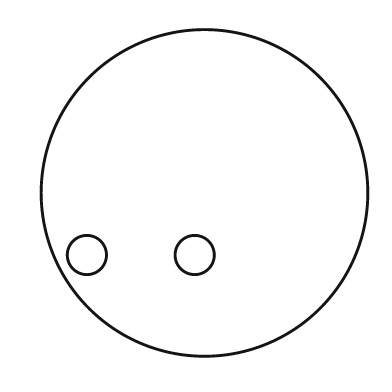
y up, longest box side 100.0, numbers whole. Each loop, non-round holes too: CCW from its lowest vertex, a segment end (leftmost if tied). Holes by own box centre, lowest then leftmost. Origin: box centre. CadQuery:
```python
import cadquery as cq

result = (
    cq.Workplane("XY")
    .moveTo(0.0, 0.0)
    .circle(50.0)
    .moveTo(-36.0, -19.0)
    .circle(6.0)
    .moveTo(-3.0, -19.0)
    .circle(6.0)
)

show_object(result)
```